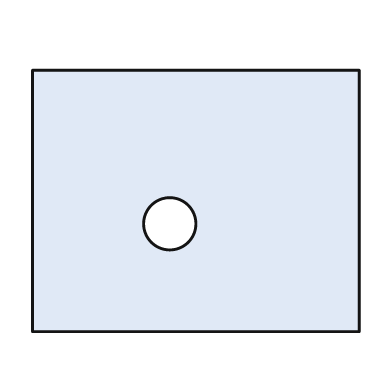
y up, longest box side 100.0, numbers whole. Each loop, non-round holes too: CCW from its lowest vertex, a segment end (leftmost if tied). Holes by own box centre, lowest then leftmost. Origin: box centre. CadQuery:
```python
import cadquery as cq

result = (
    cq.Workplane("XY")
    .moveTo(-50.0, -40.0)
    .lineTo(50.0, -40.0)
    .lineTo(50.0, 40.0)
    .lineTo(-50.0, 40.0)
    .close()
    .moveTo(-8.0, -7.0)
    .circle(8.0)
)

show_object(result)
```